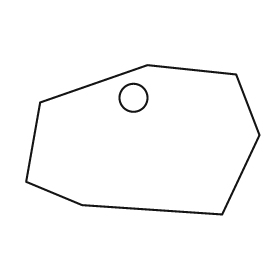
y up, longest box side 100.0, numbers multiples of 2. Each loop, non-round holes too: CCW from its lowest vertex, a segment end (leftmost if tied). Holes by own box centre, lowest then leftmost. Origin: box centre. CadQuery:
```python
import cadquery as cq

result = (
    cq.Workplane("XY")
    .moveTo(34.0, -32.0)
    .lineTo(50.0, 2.0)
    .lineTo(40.0, 28.0)
    .lineTo(2.0, 32.0)
    .lineTo(-44.0, 16.0)
    .lineTo(-50.0, -18.0)
    .lineTo(-26.0, -28.0)
    .close()
    .moveTo(-4.0, 18.0)
    .circle(6.0)
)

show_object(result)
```